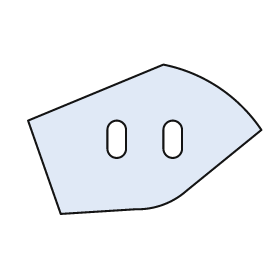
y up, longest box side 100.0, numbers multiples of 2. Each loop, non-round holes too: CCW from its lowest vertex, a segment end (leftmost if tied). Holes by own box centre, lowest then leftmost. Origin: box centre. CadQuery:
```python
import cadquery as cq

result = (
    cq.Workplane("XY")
    .moveTo(-36.0, -32.0)
    .lineTo(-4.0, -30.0)
    .threePointArc((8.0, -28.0), (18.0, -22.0))
    .lineTo(50.0, 4.0)
    .threePointArc((32.0, 22.0), (8.0, 32.0))
    .lineTo(-50.0, 8.0)
    .close()
    .moveTo(-16.0, -4.0)
    .threePointArc((-12.0, -8.0), (-8.0, -4.0))
    .lineTo(-8.0, 4.0)
    .threePointArc((-12.0, 8.0), (-16.0, 4.0))
    .close()
    .moveTo(8.0, -4.0)
    .threePointArc((12.0, -8.0), (16.0, -4.0))
    .lineTo(16.0, 4.0)
    .threePointArc((12.0, 8.0), (8.0, 4.0))
    .close()
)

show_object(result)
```